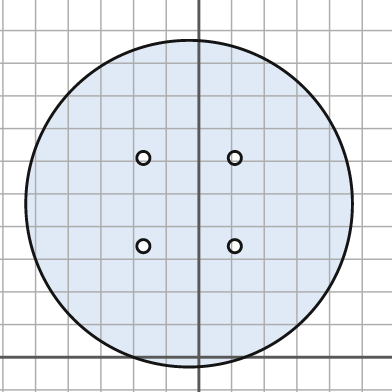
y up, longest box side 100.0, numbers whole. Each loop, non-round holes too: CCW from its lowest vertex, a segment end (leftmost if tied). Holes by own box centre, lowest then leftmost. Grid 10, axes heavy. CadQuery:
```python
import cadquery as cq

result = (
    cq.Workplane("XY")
    .moveTo(-3.0, 47.0)
    .circle(50.0)
    .moveTo(-17.0, 34.0)
    .circle(2.0)
    .moveTo(11.0, 34.0)
    .circle(2.0)
    .moveTo(-17.0, 61.0)
    .circle(2.0)
    .moveTo(11.0, 61.0)
    .circle(2.0)
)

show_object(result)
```